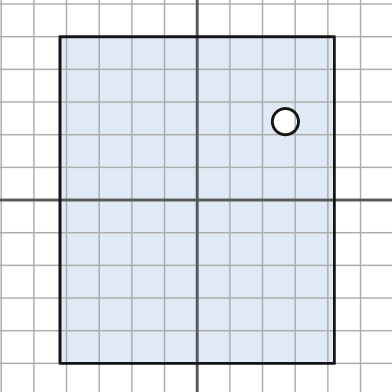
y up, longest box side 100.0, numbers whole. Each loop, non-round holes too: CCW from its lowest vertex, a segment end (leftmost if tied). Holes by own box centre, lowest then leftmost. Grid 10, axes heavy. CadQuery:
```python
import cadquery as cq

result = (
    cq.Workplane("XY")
    .moveTo(-42.0, -50.0)
    .lineTo(42.0, -50.0)
    .lineTo(42.0, 50.0)
    .lineTo(-42.0, 50.0)
    .close()
    .moveTo(27.0, 24.0)
    .circle(4.0)
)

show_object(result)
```